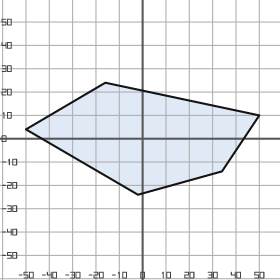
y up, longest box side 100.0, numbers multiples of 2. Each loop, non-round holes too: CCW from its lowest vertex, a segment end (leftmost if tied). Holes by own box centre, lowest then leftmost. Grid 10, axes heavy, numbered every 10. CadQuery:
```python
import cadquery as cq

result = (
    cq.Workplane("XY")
    .moveTo(-2.0, -24.0)
    .lineTo(34.0, -14.0)
    .lineTo(50.0, 10.0)
    .lineTo(-16.0, 24.0)
    .lineTo(-50.0, 4.0)
    .close()
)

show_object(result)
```